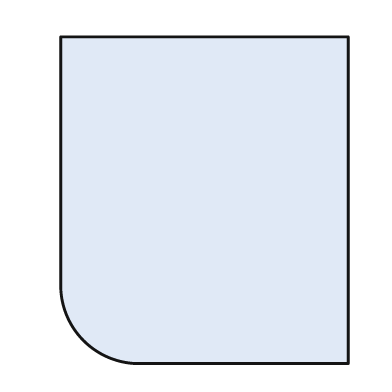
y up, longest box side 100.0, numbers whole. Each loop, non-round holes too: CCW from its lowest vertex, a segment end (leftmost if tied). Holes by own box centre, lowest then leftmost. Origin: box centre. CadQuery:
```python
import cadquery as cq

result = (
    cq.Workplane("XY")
    .moveTo(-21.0, -50.0)
    .lineTo(44.0, -50.0)
    .lineTo(44.0, 50.0)
    .lineTo(-44.0, 50.0)
    .lineTo(-44.0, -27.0)
    .threePointArc((-37.0, -43.0), (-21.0, -50.0))
    .close()
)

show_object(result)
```